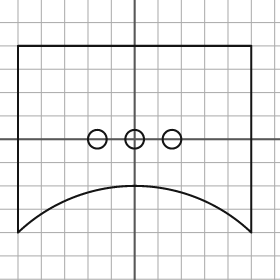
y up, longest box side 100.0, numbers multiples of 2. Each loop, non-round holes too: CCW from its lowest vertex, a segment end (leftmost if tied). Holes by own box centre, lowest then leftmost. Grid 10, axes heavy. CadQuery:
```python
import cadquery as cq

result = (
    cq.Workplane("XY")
    .moveTo(-50.0, -40.0)
    .threePointArc((0.0, -20.0), (50.0, -40.0))
    .lineTo(50.0, 40.0)
    .lineTo(-50.0, 40.0)
    .close()
    .moveTo(-16.0, 0.0)
    .circle(4.0)
    .moveTo(0.0, 0.0)
    .circle(4.0)
    .moveTo(16.0, 0.0)
    .circle(4.0)
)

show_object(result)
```